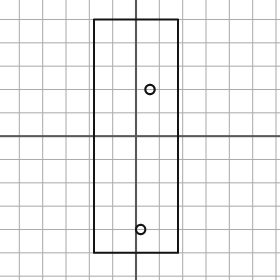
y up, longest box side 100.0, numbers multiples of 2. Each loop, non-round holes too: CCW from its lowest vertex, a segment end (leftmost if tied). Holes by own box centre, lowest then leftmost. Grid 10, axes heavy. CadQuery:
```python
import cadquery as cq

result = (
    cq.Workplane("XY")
    .moveTo(-18.0, -50.0)
    .lineTo(18.0, -50.0)
    .lineTo(18.0, 50.0)
    .lineTo(-18.0, 50.0)
    .close()
    .moveTo(2.0, -40.0)
    .circle(2.0)
    .moveTo(6.0, 20.0)
    .circle(2.0)
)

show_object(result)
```